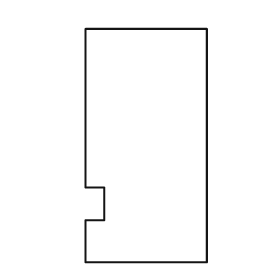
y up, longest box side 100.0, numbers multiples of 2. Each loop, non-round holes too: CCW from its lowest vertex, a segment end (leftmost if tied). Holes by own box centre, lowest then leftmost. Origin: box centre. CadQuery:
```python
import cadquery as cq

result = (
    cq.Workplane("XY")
    .moveTo(-26.0, -50.0)
    .lineTo(26.0, -50.0)
    .lineTo(26.0, 50.0)
    .lineTo(-26.0, 50.0)
    .lineTo(-26.0, -18.0)
    .lineTo(-18.0, -18.0)
    .lineTo(-18.0, -32.0)
    .lineTo(-26.0, -32.0)
    .close()
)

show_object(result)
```